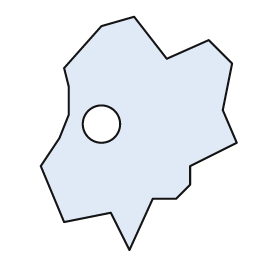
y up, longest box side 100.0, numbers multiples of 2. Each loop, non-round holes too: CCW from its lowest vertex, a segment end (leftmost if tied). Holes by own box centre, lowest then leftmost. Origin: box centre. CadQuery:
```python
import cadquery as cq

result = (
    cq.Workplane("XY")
    .moveTo(-4.0, -50.0)
    .lineTo(6.0, -28.0)
    .lineTo(16.0, -28.0)
    .lineTo(22.0, -22.0)
    .lineTo(22.0, -14.0)
    .lineTo(42.0, -4.0)
    .lineTo(36.0, 10.0)
    .lineTo(40.0, 30.0)
    .lineTo(30.0, 40.0)
    .lineTo(12.0, 32.0)
    .lineTo(-2.0, 50.0)
    .lineTo(-16.0, 46.0)
    .lineTo(-32.0, 28.0)
    .lineTo(-30.0, 20.0)
    .lineTo(-30.0, 8.0)
    .lineTo(-34.0, -2.0)
    .lineTo(-42.0, -14.0)
    .lineTo(-32.0, -38.0)
    .lineTo(-12.0, -34.0)
    .close()
    .moveTo(-16.0, 4.0)
    .circle(8.0)
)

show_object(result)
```